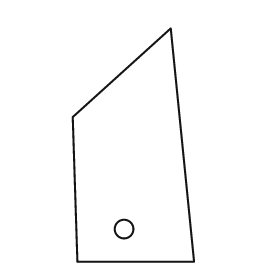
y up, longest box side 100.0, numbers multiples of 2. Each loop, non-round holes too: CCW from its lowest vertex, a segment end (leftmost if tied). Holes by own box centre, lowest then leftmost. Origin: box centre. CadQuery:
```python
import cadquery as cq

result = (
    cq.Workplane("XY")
    .moveTo(-24.0, -50.0)
    .lineTo(26.0, -50.0)
    .lineTo(16.0, 50.0)
    .lineTo(-26.0, 12.0)
    .close()
    .moveTo(-4.0, -36.0)
    .circle(4.0)
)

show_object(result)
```